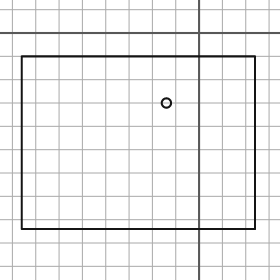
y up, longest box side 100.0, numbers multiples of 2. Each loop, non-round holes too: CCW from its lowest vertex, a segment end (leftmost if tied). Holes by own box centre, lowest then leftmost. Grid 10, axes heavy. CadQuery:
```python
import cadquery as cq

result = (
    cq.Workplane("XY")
    .moveTo(-76.0, -84.0)
    .lineTo(24.0, -84.0)
    .lineTo(24.0, -10.0)
    .lineTo(-76.0, -10.0)
    .close()
    .moveTo(-14.0, -30.0)
    .circle(2.0)
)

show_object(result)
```